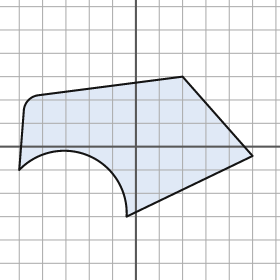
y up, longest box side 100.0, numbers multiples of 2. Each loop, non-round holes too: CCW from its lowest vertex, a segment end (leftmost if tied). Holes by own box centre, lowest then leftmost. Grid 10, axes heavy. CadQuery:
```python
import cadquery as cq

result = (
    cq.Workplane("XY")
    .moveTo(-4.0, -30.0)
    .lineTo(50.0, -4.0)
    .lineTo(20.0, 30.0)
    .lineTo(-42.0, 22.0)
    .threePointArc((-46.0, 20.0), (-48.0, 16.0))
    .lineTo(-50.0, -10.0)
    .threePointArc((-20.0, -4.0), (-4.0, -30.0))
    .close()
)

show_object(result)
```